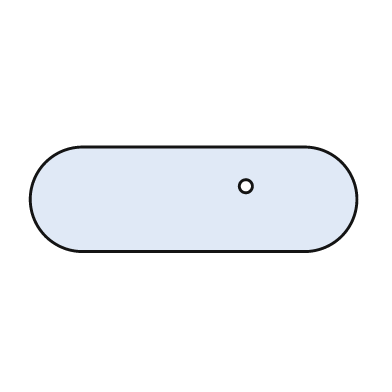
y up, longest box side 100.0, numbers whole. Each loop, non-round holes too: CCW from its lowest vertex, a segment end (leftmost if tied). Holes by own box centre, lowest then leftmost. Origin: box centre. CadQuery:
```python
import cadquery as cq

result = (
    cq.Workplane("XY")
    .moveTo(-34.0, -16.0)
    .lineTo(34.0, -16.0)
    .threePointArc((50.0, 0.0), (34.0, 16.0))
    .lineTo(-34.0, 16.0)
    .threePointArc((-50.0, 0.0), (-34.0, -16.0))
    .close()
    .moveTo(16.0, 4.0)
    .circle(2.0)
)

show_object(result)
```